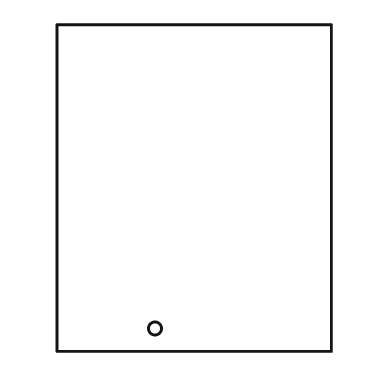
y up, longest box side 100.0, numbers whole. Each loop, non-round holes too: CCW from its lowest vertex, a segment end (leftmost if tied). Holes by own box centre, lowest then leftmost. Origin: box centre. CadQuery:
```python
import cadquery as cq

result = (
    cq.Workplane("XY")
    .moveTo(-42.0, -50.0)
    .lineTo(42.0, -50.0)
    .lineTo(42.0, 50.0)
    .lineTo(-42.0, 50.0)
    .close()
    .moveTo(-12.0, -43.0)
    .circle(2.0)
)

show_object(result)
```